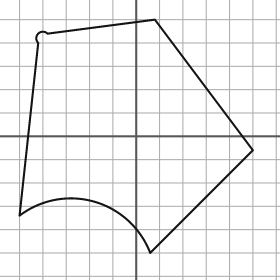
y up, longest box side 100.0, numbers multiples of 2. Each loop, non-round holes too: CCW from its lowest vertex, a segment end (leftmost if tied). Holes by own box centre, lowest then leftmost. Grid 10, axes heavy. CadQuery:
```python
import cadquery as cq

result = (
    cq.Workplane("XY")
    .moveTo(6.0, -50.0)
    .lineTo(50.0, -6.0)
    .lineTo(8.0, 50.0)
    .lineTo(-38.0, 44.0)
    .threePointArc((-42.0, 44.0), (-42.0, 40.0))
    .lineTo(-50.0, -34.0)
    .threePointArc((-18.0, -28.0), (6.0, -50.0))
    .close()
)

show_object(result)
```